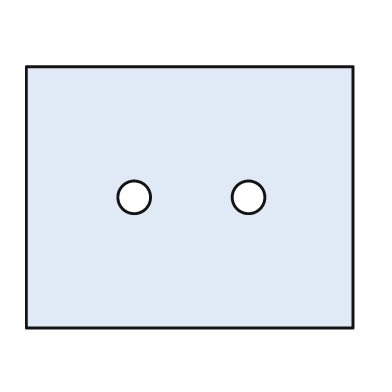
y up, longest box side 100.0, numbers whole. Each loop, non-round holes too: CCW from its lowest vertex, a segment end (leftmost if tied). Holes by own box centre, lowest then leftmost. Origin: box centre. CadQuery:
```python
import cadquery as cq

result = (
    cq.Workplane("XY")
    .moveTo(-50.0, -40.0)
    .lineTo(50.0, -40.0)
    .lineTo(50.0, 40.0)
    .lineTo(-50.0, 40.0)
    .close()
    .moveTo(-17.0, 0.0)
    .circle(5.0)
    .moveTo(18.0, 0.0)
    .circle(5.0)
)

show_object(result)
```